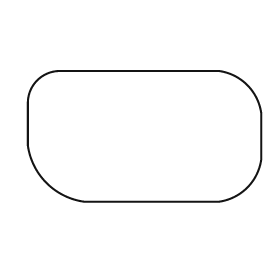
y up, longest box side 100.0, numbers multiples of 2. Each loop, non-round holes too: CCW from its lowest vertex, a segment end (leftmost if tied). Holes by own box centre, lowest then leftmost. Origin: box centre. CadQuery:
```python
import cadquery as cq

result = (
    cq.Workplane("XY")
    .moveTo(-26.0, -28.0)
    .lineTo(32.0, -28.0)
    .threePointArc((44.0, -22.0), (50.0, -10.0))
    .lineTo(50.0, 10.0)
    .threePointArc((44.0, 22.0), (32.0, 28.0))
    .lineTo(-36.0, 28.0)
    .threePointArc((-46.0, 24.0), (-50.0, 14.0))
    .lineTo(-50.0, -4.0)
    .threePointArc((-42.0, -20.0), (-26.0, -28.0))
    .close()
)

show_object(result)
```